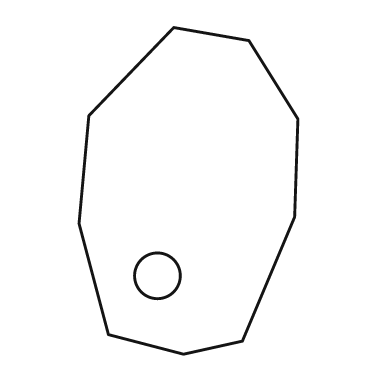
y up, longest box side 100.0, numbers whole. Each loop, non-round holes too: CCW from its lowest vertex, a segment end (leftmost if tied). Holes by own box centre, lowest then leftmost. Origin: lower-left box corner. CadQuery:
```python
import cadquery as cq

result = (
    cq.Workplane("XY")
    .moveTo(32.0, 0.0)
    .lineTo(50.0, 4.0)
    .lineTo(66.0, 42.0)
    .lineTo(67.0, 72.0)
    .lineTo(52.0, 96.0)
    .lineTo(29.0, 100.0)
    .lineTo(3.0, 73.0)
    .lineTo(0.0, 40.0)
    .lineTo(9.0, 6.0)
    .close()
    .moveTo(24.0, 24.0)
    .circle(7.0)
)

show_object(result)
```